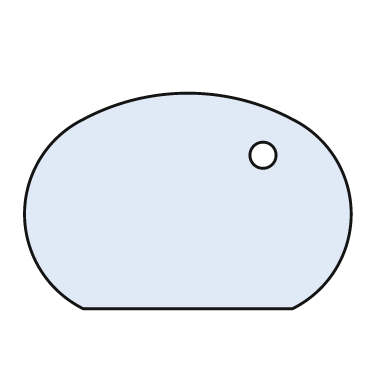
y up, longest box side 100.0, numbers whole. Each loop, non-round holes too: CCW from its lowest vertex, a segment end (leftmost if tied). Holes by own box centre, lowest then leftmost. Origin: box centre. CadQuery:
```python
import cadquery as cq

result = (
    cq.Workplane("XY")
    .moveTo(-32.0, -33.0)
    .lineTo(32.0, -33.0)
    .threePointArc((50.0, -4.0), (32.0, 25.0))
    .threePointArc((0.0, 33.0), (-32.0, 25.0))
    .threePointArc((-50.0, -4.0), (-32.0, -33.0))
    .close()
    .moveTo(23.0, 14.0)
    .circle(4.0)
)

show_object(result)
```